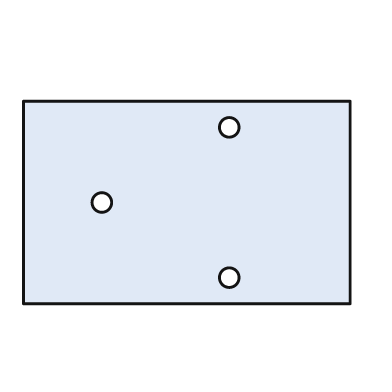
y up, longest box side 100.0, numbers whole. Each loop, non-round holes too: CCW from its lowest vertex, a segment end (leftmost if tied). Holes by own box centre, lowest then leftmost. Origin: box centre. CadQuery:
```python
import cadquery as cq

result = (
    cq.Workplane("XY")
    .moveTo(-50.0, -31.0)
    .lineTo(50.0, -31.0)
    .lineTo(50.0, 31.0)
    .lineTo(-50.0, 31.0)
    .close()
    .moveTo(13.0, -23.0)
    .circle(3.0)
    .moveTo(-26.0, 0.0)
    .circle(3.0)
    .moveTo(13.0, 23.0)
    .circle(3.0)
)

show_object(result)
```